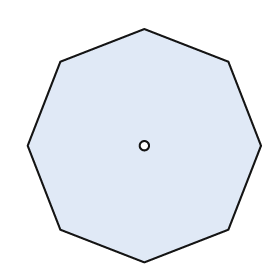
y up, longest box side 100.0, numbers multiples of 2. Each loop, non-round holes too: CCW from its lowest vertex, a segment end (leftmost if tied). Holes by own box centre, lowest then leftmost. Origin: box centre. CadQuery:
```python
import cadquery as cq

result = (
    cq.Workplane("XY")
    .moveTo(0.0, -50.0)
    .lineTo(36.0, -36.0)
    .lineTo(50.0, 0.0)
    .lineTo(36.0, 36.0)
    .lineTo(0.0, 50.0)
    .lineTo(-36.0, 36.0)
    .lineTo(-50.0, 0.0)
    .lineTo(-36.0, -36.0)
    .close()
    .moveTo(0.0, 0.0)
    .circle(2.0)
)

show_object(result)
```